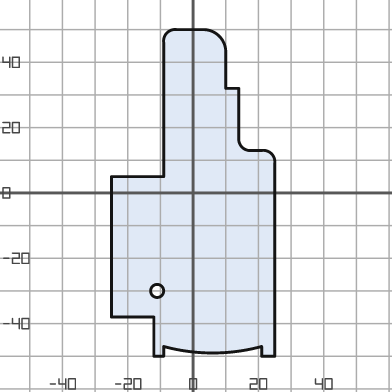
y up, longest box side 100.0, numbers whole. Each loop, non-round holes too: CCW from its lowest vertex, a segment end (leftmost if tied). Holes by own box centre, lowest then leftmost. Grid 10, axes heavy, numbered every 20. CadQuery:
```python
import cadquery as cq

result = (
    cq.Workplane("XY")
    .moveTo(-12.0, -50.0)
    .lineTo(-9.0, -50.0)
    .lineTo(-9.0, -47.0)
    .threePointArc((6.0, -49.0), (21.0, -47.0))
    .lineTo(21.0, -50.0)
    .lineTo(25.0, -50.0)
    .lineTo(25.0, 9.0)
    .threePointArc((24.0, 12.0), (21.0, 13.0))
    .lineTo(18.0, 13.0)
    .threePointArc((15.0, 14.0), (14.0, 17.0))
    .lineTo(14.0, 32.0)
    .lineTo(10.0, 32.0)
    .lineTo(10.0, 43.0)
    .threePointArc((8.0, 48.0), (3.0, 50.0))
    .lineTo(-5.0, 50.0)
    .threePointArc((-8.0, 49.0), (-9.0, 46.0))
    .lineTo(-9.0, 5.0)
    .lineTo(-25.0, 5.0)
    .lineTo(-25.0, -38.0)
    .lineTo(-12.0, -38.0)
    .close()
    .moveTo(-11.0, -30.0)
    .circle(2.0)
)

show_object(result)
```